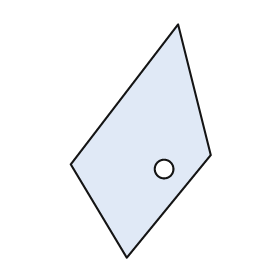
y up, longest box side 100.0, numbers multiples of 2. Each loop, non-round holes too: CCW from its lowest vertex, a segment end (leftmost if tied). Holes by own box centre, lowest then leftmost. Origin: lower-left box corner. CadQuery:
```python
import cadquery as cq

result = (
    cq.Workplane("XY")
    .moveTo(24.0, 0.0)
    .lineTo(60.0, 44.0)
    .lineTo(46.0, 100.0)
    .lineTo(0.0, 40.0)
    .close()
    .moveTo(40.0, 38.0)
    .circle(4.0)
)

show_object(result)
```